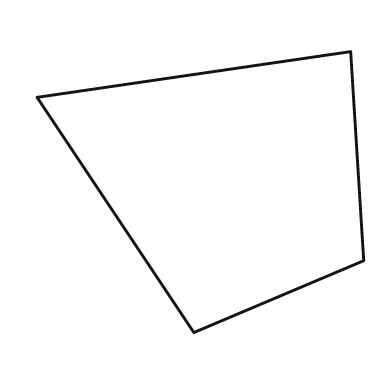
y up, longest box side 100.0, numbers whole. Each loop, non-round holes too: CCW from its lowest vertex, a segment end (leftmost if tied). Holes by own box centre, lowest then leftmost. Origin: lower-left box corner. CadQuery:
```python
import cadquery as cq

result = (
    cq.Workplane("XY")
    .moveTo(48.0, 0.0)
    .lineTo(100.0, 22.0)
    .lineTo(96.0, 86.0)
    .lineTo(0.0, 72.0)
    .close()
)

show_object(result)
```